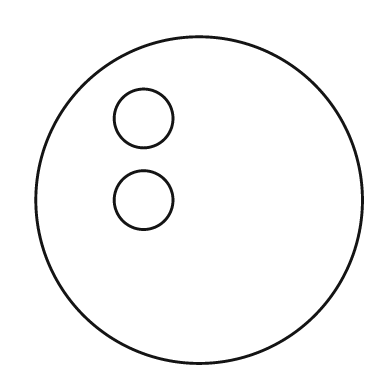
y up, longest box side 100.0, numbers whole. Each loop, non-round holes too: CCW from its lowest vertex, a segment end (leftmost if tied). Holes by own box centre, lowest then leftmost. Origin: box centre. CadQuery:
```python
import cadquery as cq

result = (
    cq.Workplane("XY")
    .moveTo(0.0, 0.0)
    .circle(50.0)
    .moveTo(-17.0, 0.0)
    .circle(9.0)
    .moveTo(-17.0, 25.0)
    .circle(9.0)
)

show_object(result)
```